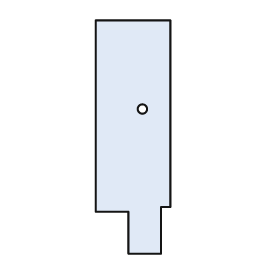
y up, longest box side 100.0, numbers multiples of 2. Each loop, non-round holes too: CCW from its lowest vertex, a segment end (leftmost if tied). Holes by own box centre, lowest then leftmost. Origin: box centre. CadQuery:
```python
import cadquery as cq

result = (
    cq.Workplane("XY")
    .moveTo(-2.0, -50.0)
    .lineTo(12.0, -50.0)
    .lineTo(12.0, -30.0)
    .lineTo(16.0, -30.0)
    .lineTo(16.0, 50.0)
    .lineTo(-16.0, 50.0)
    .lineTo(-16.0, -32.0)
    .lineTo(-2.0, -32.0)
    .close()
    .moveTo(4.0, 12.0)
    .circle(2.0)
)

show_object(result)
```